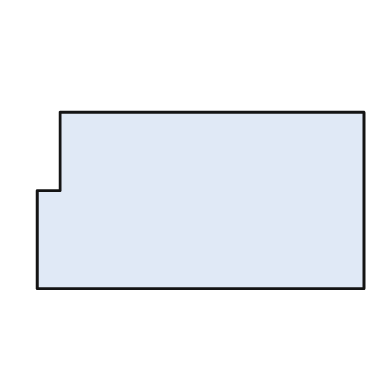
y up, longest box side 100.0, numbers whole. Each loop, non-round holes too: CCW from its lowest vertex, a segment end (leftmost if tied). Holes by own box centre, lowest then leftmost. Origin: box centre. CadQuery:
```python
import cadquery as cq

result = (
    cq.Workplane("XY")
    .moveTo(-50.0, -27.0)
    .lineTo(50.0, -27.0)
    .lineTo(50.0, 27.0)
    .lineTo(-43.0, 27.0)
    .lineTo(-43.0, 3.0)
    .lineTo(-50.0, 3.0)
    .close()
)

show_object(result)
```